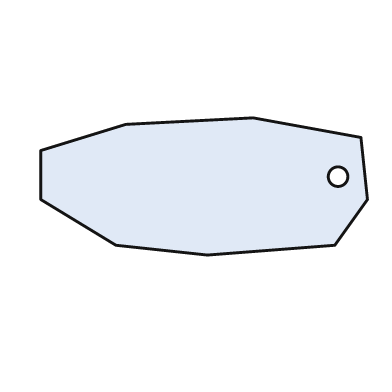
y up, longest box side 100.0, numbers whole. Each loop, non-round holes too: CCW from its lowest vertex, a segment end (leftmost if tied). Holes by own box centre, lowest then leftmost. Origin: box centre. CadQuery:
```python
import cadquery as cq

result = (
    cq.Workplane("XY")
    .moveTo(1.0, -21.0)
    .lineTo(40.0, -18.0)
    .lineTo(50.0, -4.0)
    .lineTo(48.0, 15.0)
    .lineTo(15.0, 21.0)
    .lineTo(-24.0, 19.0)
    .lineTo(-50.0, 11.0)
    .lineTo(-50.0, -4.0)
    .lineTo(-27.0, -18.0)
    .close()
    .moveTo(41.0, 3.0)
    .circle(3.0)
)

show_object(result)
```